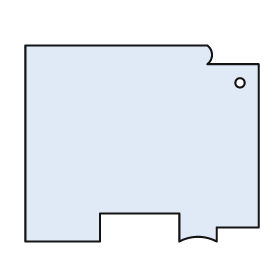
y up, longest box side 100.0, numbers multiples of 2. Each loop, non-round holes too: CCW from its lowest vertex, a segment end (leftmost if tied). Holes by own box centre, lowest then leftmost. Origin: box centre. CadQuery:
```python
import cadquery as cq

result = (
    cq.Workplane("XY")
    .moveTo(-50.0, -42.0)
    .lineTo(-18.0, -42.0)
    .lineTo(-18.0, -30.0)
    .lineTo(16.0, -30.0)
    .lineTo(16.0, -42.0)
    .threePointArc((24.0, -40.0), (32.0, -42.0))
    .lineTo(32.0, -36.0)
    .lineTo(50.0, -36.0)
    .lineTo(50.0, 34.0)
    .lineTo(28.0, 34.0)
    .threePointArc((30.0, 38.0), (28.0, 42.0))
    .lineTo(-50.0, 42.0)
    .close()
    .moveTo(42.0, 26.0)
    .circle(2.0)
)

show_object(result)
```